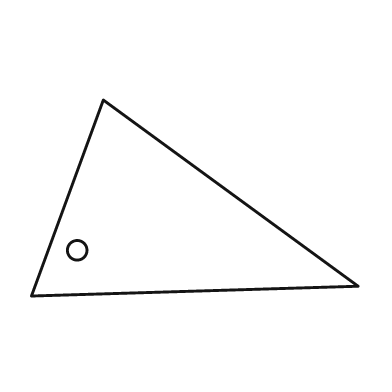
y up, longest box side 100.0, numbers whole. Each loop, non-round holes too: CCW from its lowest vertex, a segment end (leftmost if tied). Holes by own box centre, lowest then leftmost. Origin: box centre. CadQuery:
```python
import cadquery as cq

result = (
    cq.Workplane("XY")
    .moveTo(-50.0, -30.0)
    .lineTo(50.0, -27.0)
    .lineTo(-28.0, 30.0)
    .close()
    .moveTo(-36.0, -16.0)
    .circle(3.0)
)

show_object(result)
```